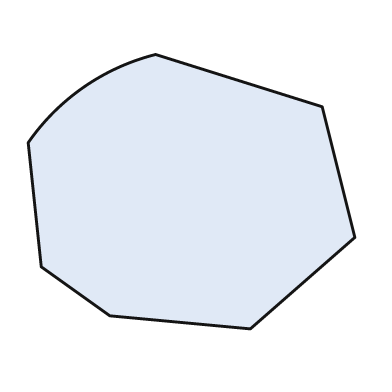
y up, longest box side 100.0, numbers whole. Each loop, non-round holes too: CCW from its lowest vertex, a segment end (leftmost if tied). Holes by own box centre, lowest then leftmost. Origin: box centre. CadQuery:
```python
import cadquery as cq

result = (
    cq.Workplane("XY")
    .moveTo(18.0, -42.0)
    .lineTo(50.0, -14.0)
    .lineTo(40.0, 26.0)
    .lineTo(-11.0, 42.0)
    .threePointArc((-33.0, 32.0), (-50.0, 15.0))
    .lineTo(-46.0, -23.0)
    .lineTo(-25.0, -38.0)
    .close()
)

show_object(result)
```